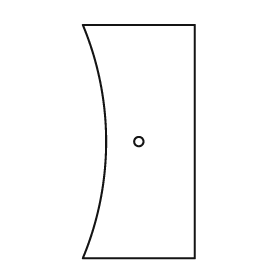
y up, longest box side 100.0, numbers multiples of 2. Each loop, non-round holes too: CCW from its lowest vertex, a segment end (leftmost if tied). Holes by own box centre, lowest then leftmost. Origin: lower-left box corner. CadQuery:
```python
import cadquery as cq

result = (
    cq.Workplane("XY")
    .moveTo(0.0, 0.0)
    .lineTo(48.0, 0.0)
    .lineTo(48.0, 100.0)
    .lineTo(0.0, 100.0)
    .threePointArc((10.0, 50.0), (0.0, 0.0))
    .close()
    .moveTo(24.0, 50.0)
    .circle(2.0)
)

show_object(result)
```